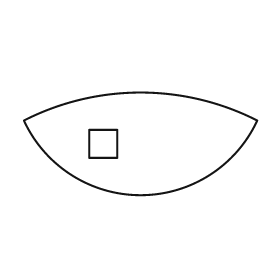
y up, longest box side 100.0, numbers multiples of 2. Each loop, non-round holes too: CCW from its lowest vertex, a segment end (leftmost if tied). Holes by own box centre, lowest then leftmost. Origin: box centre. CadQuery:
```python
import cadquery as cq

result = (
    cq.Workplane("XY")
    .moveTo(-50.0, 10.0)
    .threePointArc((0.0, -22.0), (50.0, 10.0))
    .threePointArc((0.0, 22.0), (-50.0, 10.0))
    .close()
    .moveTo(-22.0, -6.0)
    .lineTo(-10.0, -6.0)
    .lineTo(-10.0, 6.0)
    .lineTo(-22.0, 6.0)
    .close()
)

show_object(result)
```